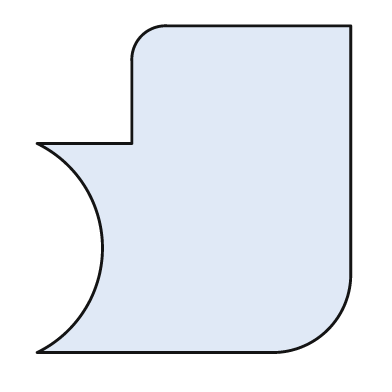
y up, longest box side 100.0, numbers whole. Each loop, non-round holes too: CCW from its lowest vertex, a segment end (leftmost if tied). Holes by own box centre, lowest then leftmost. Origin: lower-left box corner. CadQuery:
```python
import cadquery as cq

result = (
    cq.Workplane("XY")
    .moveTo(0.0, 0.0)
    .lineTo(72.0, 0.0)
    .threePointArc((89.0, 7.0), (96.0, 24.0))
    .lineTo(96.0, 100.0)
    .lineTo(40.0, 100.0)
    .threePointArc((32.0, 97.0), (29.0, 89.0))
    .lineTo(29.0, 64.0)
    .lineTo(0.0, 64.0)
    .threePointArc((20.0, 32.0), (0.0, 0.0))
    .close()
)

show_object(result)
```